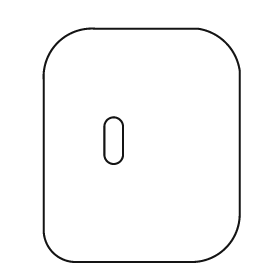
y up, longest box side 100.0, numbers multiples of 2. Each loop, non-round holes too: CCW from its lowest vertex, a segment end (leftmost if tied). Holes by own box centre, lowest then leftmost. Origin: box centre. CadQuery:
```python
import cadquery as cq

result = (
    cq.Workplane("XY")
    .moveTo(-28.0, -50.0)
    .lineTo(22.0, -50.0)
    .threePointArc((36.0, -44.0), (42.0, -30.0))
    .lineTo(42.0, 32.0)
    .threePointArc((36.0, 44.0), (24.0, 50.0))
    .lineTo(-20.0, 50.0)
    .threePointArc((-36.0, 44.0), (-42.0, 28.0))
    .lineTo(-42.0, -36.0)
    .threePointArc((-38.0, -46.0), (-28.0, -50.0))
    .close()
    .moveTo(-16.0, -4.0)
    .threePointArc((-12.0, -8.0), (-8.0, -4.0))
    .lineTo(-8.0, 8.0)
    .threePointArc((-12.0, 12.0), (-16.0, 8.0))
    .close()
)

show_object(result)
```